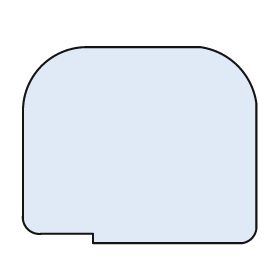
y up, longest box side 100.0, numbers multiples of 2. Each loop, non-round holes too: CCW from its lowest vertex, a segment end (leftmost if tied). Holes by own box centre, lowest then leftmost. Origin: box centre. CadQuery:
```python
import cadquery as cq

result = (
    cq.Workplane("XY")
    .moveTo(-20.0, -42.0)
    .lineTo(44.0, -42.0)
    .threePointArc((48.0, -40.0), (50.0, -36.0))
    .lineTo(50.0, 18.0)
    .threePointArc((42.0, 34.0), (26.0, 42.0))
    .lineTo(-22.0, 42.0)
    .threePointArc((-42.0, 34.0), (-50.0, 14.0))
    .lineTo(-50.0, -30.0)
    .threePointArc((-48.0, -36.0), (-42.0, -38.0))
    .lineTo(-20.0, -38.0)
    .close()
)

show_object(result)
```